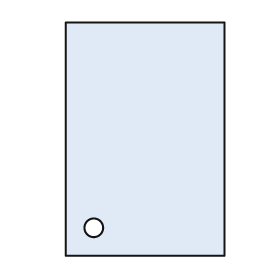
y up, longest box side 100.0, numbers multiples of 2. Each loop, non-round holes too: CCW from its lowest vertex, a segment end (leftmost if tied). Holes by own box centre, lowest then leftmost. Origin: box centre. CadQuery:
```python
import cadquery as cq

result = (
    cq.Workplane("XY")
    .moveTo(-34.0, -50.0)
    .lineTo(34.0, -50.0)
    .lineTo(34.0, 50.0)
    .lineTo(-34.0, 50.0)
    .close()
    .moveTo(-22.0, -38.0)
    .circle(4.0)
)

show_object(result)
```